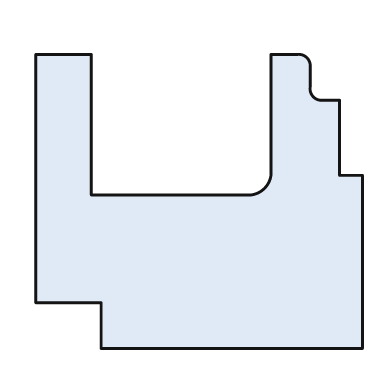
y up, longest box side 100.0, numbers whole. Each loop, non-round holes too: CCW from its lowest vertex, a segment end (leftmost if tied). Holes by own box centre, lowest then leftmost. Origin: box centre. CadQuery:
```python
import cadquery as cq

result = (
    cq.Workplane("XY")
    .moveTo(-30.0, -45.0)
    .lineTo(50.0, -45.0)
    .lineTo(50.0, 8.0)
    .lineTo(43.0, 8.0)
    .lineTo(43.0, 31.0)
    .lineTo(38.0, 31.0)
    .threePointArc((35.0, 32.0), (34.0, 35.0))
    .lineTo(34.0, 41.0)
    .threePointArc((33.0, 44.0), (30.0, 45.0))
    .lineTo(22.0, 45.0)
    .lineTo(22.0, 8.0)
    .threePointArc((20.0, 4.0), (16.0, 2.0))
    .lineTo(-33.0, 2.0)
    .lineTo(-33.0, 45.0)
    .lineTo(-50.0, 45.0)
    .lineTo(-50.0, -31.0)
    .lineTo(-30.0, -31.0)
    .close()
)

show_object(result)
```